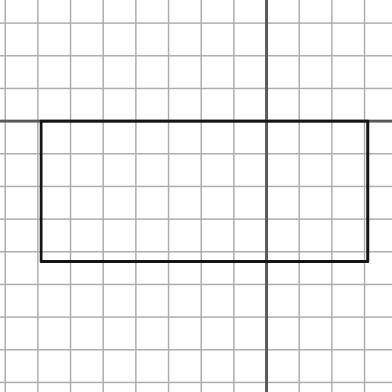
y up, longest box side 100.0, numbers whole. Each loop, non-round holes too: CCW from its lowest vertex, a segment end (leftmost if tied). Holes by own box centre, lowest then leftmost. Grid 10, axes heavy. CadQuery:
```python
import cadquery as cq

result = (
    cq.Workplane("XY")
    .moveTo(-69.0, -43.0)
    .lineTo(31.0, -43.0)
    .lineTo(31.0, 0.0)
    .lineTo(-69.0, 0.0)
    .close()
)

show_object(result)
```